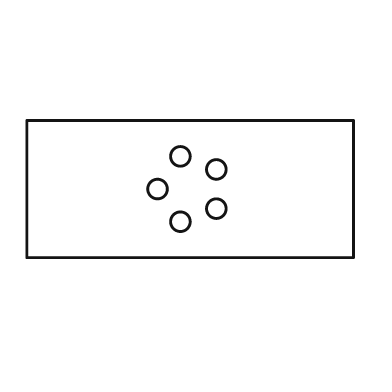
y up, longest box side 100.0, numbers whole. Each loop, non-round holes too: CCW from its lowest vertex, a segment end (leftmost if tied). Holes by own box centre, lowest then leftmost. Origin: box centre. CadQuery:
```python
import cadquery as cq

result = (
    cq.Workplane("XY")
    .moveTo(-50.0, -21.0)
    .lineTo(50.0, -21.0)
    .lineTo(50.0, 21.0)
    .lineTo(-50.0, 21.0)
    .close()
    .moveTo(-3.0, -10.0)
    .circle(3.0)
    .moveTo(8.0, -6.0)
    .circle(3.0)
    .moveTo(-10.0, 0.0)
    .circle(3.0)
    .moveTo(8.0, 6.0)
    .circle(3.0)
    .moveTo(-3.0, 10.0)
    .circle(3.0)
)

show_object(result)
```